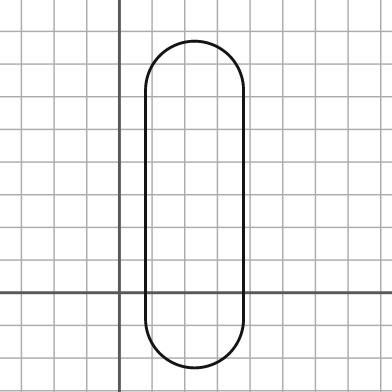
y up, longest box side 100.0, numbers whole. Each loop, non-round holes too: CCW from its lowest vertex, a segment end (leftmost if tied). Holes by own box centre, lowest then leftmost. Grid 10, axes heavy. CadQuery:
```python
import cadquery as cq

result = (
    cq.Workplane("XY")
    .moveTo(8.0, -8.0)
    .threePointArc((23.0, -23.0), (38.0, -8.0))
    .lineTo(38.0, 62.0)
    .threePointArc((23.0, 77.0), (8.0, 62.0))
    .close()
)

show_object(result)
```